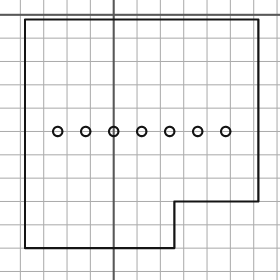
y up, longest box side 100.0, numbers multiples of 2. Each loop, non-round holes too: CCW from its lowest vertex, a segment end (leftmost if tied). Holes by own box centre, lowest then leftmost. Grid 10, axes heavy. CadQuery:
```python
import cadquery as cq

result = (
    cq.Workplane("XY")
    .moveTo(-38.0, -100.0)
    .lineTo(26.0, -100.0)
    .lineTo(26.0, -80.0)
    .lineTo(62.0, -80.0)
    .lineTo(62.0, -2.0)
    .lineTo(-38.0, -2.0)
    .close()
    .moveTo(-24.0, -50.0)
    .circle(2.0)
    .moveTo(-12.0, -50.0)
    .circle(2.0)
    .moveTo(0.0, -50.0)
    .circle(2.0)
    .moveTo(12.0, -50.0)
    .circle(2.0)
    .moveTo(24.0, -50.0)
    .circle(2.0)
    .moveTo(36.0, -50.0)
    .circle(2.0)
    .moveTo(48.0, -50.0)
    .circle(2.0)
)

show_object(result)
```